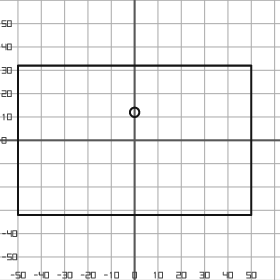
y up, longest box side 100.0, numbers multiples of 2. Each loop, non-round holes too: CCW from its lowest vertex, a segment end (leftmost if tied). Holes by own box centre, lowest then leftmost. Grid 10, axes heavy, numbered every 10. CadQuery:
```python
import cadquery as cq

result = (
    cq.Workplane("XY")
    .moveTo(-50.0, -32.0)
    .lineTo(50.0, -32.0)
    .lineTo(50.0, 32.0)
    .lineTo(-50.0, 32.0)
    .close()
    .moveTo(0.0, 12.0)
    .circle(2.0)
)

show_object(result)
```